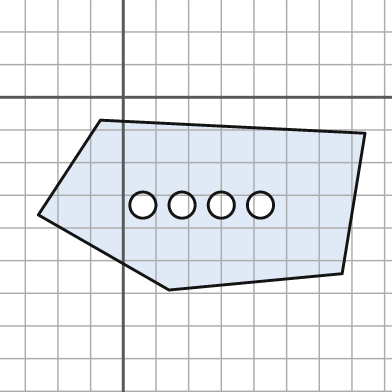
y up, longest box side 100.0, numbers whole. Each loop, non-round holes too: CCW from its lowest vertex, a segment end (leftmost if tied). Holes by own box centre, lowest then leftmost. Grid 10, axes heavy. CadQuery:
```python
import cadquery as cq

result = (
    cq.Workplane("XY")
    .moveTo(14.0, -59.0)
    .lineTo(67.0, -54.0)
    .lineTo(74.0, -11.0)
    .lineTo(-7.0, -7.0)
    .lineTo(-26.0, -36.0)
    .close()
    .moveTo(6.0, -33.0)
    .circle(4.0)
    .moveTo(18.0, -33.0)
    .circle(4.0)
    .moveTo(30.0, -33.0)
    .circle(4.0)
    .moveTo(42.0, -33.0)
    .circle(4.0)
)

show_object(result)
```